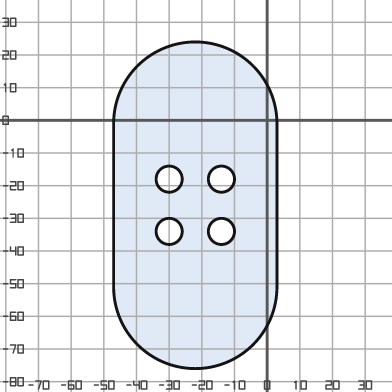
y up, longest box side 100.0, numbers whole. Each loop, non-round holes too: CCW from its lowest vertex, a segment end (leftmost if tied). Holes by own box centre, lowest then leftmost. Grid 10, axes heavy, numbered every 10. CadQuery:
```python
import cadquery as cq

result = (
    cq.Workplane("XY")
    .moveTo(-47.0, -51.0)
    .threePointArc((-22.0, -76.0), (3.0, -51.0))
    .lineTo(3.0, -1.0)
    .threePointArc((-22.0, 24.0), (-47.0, -1.0))
    .close()
    .moveTo(-30.0, -34.0)
    .circle(4.0)
    .moveTo(-14.0, -34.0)
    .circle(4.0)
    .moveTo(-30.0, -18.0)
    .circle(4.0)
    .moveTo(-14.0, -18.0)
    .circle(4.0)
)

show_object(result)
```